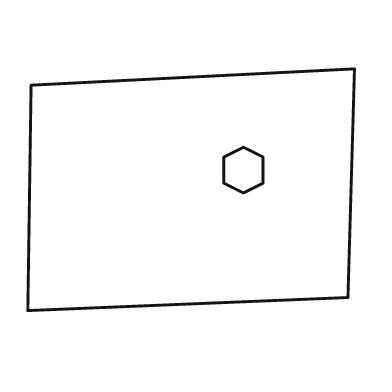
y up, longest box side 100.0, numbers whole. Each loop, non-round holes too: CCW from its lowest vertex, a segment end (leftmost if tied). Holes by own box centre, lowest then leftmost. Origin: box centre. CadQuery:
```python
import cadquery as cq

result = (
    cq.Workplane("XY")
    .moveTo(-50.0, -37.0)
    .lineTo(48.0, -33.0)
    .lineTo(50.0, 37.0)
    .lineTo(-49.0, 32.0)
    .close()
    .moveTo(16.0, -1.0)
    .lineTo(22.0, 2.0)
    .lineTo(22.0, 10.0)
    .lineTo(16.0, 13.0)
    .lineTo(10.0, 10.0)
    .lineTo(10.0, 2.0)
    .close()
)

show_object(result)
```